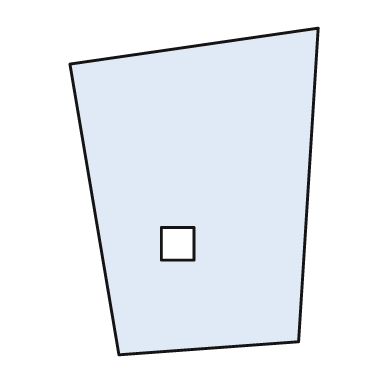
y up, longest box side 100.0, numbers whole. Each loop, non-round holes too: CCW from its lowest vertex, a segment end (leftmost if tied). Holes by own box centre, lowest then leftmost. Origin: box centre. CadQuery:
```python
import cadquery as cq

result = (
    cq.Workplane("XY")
    .moveTo(-23.0, -50.0)
    .lineTo(32.0, -46.0)
    .lineTo(38.0, 50.0)
    .lineTo(-38.0, 39.0)
    .close()
    .moveTo(-10.0, -21.0)
    .lineTo(0.0, -21.0)
    .lineTo(0.0, -11.0)
    .lineTo(-10.0, -11.0)
    .close()
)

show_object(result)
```